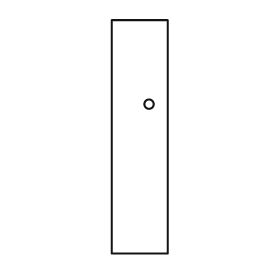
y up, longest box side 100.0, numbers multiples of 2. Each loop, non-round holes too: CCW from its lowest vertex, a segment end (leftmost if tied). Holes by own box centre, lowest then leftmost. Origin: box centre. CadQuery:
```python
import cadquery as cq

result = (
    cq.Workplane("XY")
    .moveTo(-12.0, -50.0)
    .lineTo(12.0, -50.0)
    .lineTo(12.0, 50.0)
    .lineTo(-12.0, 50.0)
    .close()
    .moveTo(4.0, 14.0)
    .circle(2.0)
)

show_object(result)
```